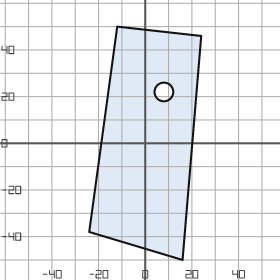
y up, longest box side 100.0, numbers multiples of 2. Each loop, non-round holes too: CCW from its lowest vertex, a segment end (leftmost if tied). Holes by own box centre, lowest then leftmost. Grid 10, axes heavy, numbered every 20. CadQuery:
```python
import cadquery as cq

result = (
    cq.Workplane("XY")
    .moveTo(16.0, -50.0)
    .lineTo(24.0, 46.0)
    .lineTo(-12.0, 50.0)
    .lineTo(-24.0, -38.0)
    .close()
    .moveTo(8.0, 22.0)
    .circle(4.0)
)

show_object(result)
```